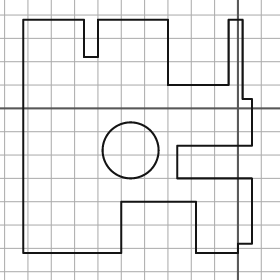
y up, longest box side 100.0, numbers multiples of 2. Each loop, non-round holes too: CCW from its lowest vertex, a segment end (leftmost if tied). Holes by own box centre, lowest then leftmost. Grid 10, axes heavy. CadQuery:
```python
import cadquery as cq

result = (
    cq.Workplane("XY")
    .moveTo(-92.0, -62.0)
    .lineTo(-50.0, -62.0)
    .lineTo(-50.0, -40.0)
    .lineTo(-18.0, -40.0)
    .lineTo(-18.0, -62.0)
    .lineTo(0.0, -62.0)
    .lineTo(0.0, -58.0)
    .lineTo(6.0, -58.0)
    .lineTo(6.0, -30.0)
    .lineTo(-26.0, -30.0)
    .lineTo(-26.0, -16.0)
    .lineTo(6.0, -16.0)
    .lineTo(6.0, 4.0)
    .lineTo(2.0, 4.0)
    .lineTo(2.0, 38.0)
    .lineTo(-4.0, 38.0)
    .lineTo(-4.0, 10.0)
    .lineTo(-30.0, 10.0)
    .lineTo(-30.0, 38.0)
    .lineTo(-60.0, 38.0)
    .lineTo(-60.0, 22.0)
    .lineTo(-66.0, 22.0)
    .lineTo(-66.0, 38.0)
    .lineTo(-92.0, 38.0)
    .close()
    .moveTo(-46.0, -18.0)
    .circle(12.0)
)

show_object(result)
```